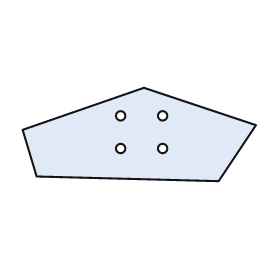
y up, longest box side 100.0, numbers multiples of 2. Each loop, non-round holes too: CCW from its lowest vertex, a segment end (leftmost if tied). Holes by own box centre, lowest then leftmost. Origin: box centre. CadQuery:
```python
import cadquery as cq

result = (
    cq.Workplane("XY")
    .moveTo(34.0, -20.0)
    .lineTo(50.0, 4.0)
    .lineTo(2.0, 20.0)
    .lineTo(-50.0, 2.0)
    .lineTo(-44.0, -18.0)
    .close()
    .moveTo(-8.0, -6.0)
    .circle(2.0)
    .moveTo(10.0, -6.0)
    .circle(2.0)
    .moveTo(-8.0, 8.0)
    .circle(2.0)
    .moveTo(10.0, 8.0)
    .circle(2.0)
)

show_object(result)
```